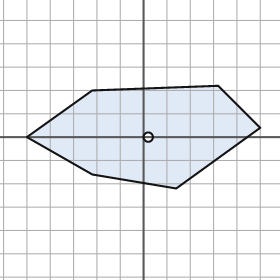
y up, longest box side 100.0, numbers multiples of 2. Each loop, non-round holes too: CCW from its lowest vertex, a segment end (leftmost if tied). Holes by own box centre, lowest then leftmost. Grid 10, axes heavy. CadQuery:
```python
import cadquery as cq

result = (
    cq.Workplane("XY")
    .moveTo(14.0, -22.0)
    .lineTo(50.0, 4.0)
    .lineTo(32.0, 22.0)
    .lineTo(-22.0, 20.0)
    .lineTo(-50.0, 0.0)
    .lineTo(-22.0, -16.0)
    .close()
    .moveTo(2.0, 0.0)
    .circle(2.0)
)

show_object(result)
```